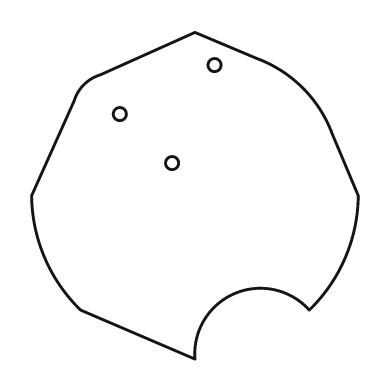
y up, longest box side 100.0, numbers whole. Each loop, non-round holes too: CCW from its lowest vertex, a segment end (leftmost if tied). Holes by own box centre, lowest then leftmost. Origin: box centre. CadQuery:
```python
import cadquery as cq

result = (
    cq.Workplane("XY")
    .moveTo(0.0, -50.0)
    .threePointArc((12.0, -30.0), (35.0, -35.0))
    .threePointArc((46.0, -19.0), (50.0, 0.0))
    .lineTo(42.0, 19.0)
    .threePointArc((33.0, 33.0), (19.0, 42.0))
    .lineTo(0.0, 50.0)
    .lineTo(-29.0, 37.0)
    .threePointArc((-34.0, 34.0), (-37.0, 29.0))
    .lineTo(-50.0, 0.0)
    .threePointArc((-46.0, -19.0), (-35.0, -35.0))
    .close()
    .moveTo(-7.0, 10.0)
    .circle(2.0)
    .moveTo(-23.0, 25.0)
    .circle(2.0)
    .moveTo(6.0, 40.0)
    .circle(2.0)
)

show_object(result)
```